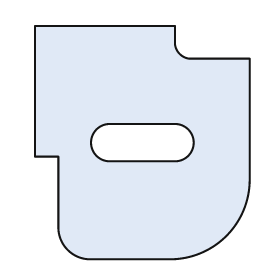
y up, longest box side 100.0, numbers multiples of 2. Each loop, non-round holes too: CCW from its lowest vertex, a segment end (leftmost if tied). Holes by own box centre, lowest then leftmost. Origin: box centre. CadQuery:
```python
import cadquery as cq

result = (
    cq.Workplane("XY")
    .moveTo(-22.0, -50.0)
    .lineTo(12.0, -50.0)
    .threePointArc((36.0, -40.0), (46.0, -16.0))
    .lineTo(46.0, 36.0)
    .lineTo(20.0, 36.0)
    .threePointArc((16.0, 38.0), (14.0, 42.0))
    .lineTo(14.0, 50.0)
    .lineTo(-46.0, 50.0)
    .lineTo(-46.0, -6.0)
    .lineTo(-36.0, -6.0)
    .lineTo(-36.0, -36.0)
    .threePointArc((-32.0, -46.0), (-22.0, -50.0))
    .close()
    .moveTo(-14.0, -8.0)
    .lineTo(14.0, -8.0)
    .threePointArc((22.0, 0.0), (14.0, 8.0))
    .lineTo(-14.0, 8.0)
    .threePointArc((-22.0, 0.0), (-14.0, -8.0))
    .close()
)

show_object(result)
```